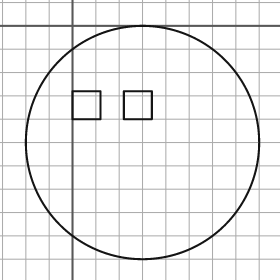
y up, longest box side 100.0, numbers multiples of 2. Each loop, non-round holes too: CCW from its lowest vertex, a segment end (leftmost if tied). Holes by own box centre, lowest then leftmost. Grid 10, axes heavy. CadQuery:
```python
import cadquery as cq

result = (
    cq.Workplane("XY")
    .moveTo(30.0, -50.0)
    .circle(50.0)
    .moveTo(0.0, -40.0)
    .lineTo(12.0, -40.0)
    .lineTo(12.0, -28.0)
    .lineTo(0.0, -28.0)
    .close()
    .moveTo(22.0, -40.0)
    .lineTo(34.0, -40.0)
    .lineTo(34.0, -28.0)
    .lineTo(22.0, -28.0)
    .close()
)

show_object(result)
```